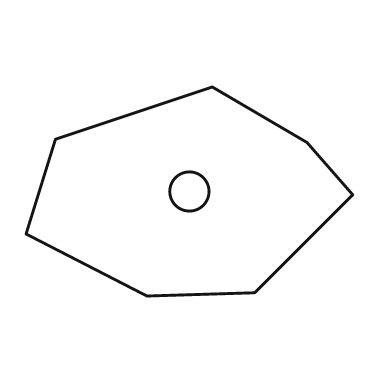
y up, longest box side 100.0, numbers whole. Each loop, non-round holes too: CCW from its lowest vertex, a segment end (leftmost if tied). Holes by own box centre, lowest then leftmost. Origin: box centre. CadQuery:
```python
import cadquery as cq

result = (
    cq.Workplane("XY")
    .moveTo(-13.0, -32.0)
    .lineTo(20.0, -31.0)
    .lineTo(50.0, -1.0)
    .lineTo(36.0, 15.0)
    .lineTo(7.0, 32.0)
    .lineTo(-41.0, 16.0)
    .lineTo(-50.0, -13.0)
    .close()
    .moveTo(0.0, 0.0)
    .circle(6.0)
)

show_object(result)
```